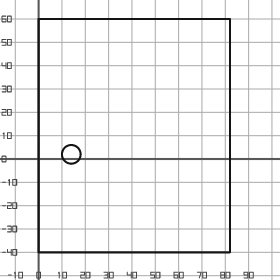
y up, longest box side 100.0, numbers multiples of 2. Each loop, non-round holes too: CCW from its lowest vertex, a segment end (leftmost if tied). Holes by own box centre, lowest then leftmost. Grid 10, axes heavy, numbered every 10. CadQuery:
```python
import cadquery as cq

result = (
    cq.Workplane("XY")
    .moveTo(0.0, -40.0)
    .lineTo(82.0, -40.0)
    .lineTo(82.0, 60.0)
    .lineTo(0.0, 60.0)
    .close()
    .moveTo(14.0, 2.0)
    .circle(4.0)
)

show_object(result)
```